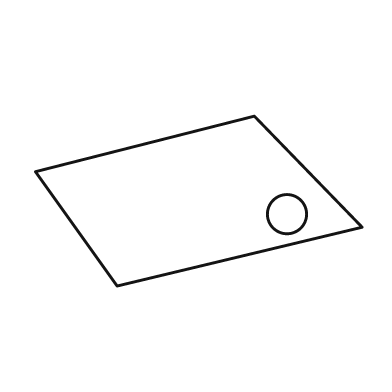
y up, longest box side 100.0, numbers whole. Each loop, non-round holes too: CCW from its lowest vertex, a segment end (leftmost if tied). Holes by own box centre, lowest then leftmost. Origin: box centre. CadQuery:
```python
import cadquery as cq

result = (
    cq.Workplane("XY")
    .moveTo(-25.0, -26.0)
    .lineTo(50.0, -8.0)
    .lineTo(17.0, 26.0)
    .lineTo(-50.0, 9.0)
    .close()
    .moveTo(27.0, -4.0)
    .circle(6.0)
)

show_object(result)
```